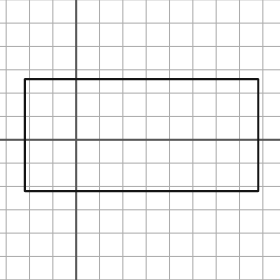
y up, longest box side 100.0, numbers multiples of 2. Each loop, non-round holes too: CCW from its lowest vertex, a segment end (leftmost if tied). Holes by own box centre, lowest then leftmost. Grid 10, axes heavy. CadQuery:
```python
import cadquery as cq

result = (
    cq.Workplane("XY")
    .moveTo(-22.0, -22.0)
    .lineTo(78.0, -22.0)
    .lineTo(78.0, 26.0)
    .lineTo(-22.0, 26.0)
    .close()
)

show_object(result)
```